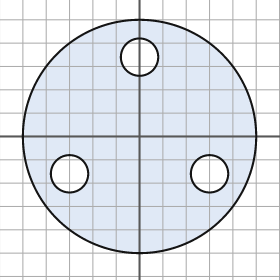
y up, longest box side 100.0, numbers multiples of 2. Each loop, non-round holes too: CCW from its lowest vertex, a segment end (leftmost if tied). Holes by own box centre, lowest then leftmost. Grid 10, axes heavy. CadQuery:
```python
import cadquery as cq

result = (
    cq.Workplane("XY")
    .moveTo(0.0, 0.0)
    .circle(50.0)
    .moveTo(-30.0, -16.0)
    .circle(8.0)
    .moveTo(30.0, -16.0)
    .circle(8.0)
    .moveTo(0.0, 34.0)
    .circle(8.0)
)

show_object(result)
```